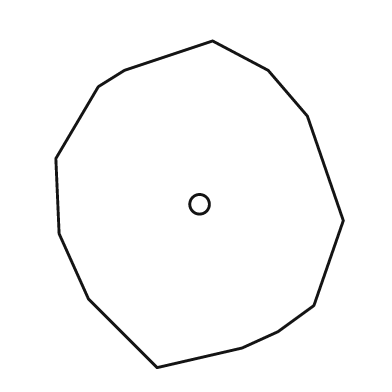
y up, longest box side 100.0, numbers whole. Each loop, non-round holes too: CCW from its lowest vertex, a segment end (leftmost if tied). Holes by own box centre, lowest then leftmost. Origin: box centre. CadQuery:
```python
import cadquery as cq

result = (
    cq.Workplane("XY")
    .moveTo(-13.0, -50.0)
    .lineTo(13.0, -44.0)
    .lineTo(24.0, -39.0)
    .lineTo(35.0, -31.0)
    .lineTo(44.0, -5.0)
    .lineTo(33.0, 27.0)
    .lineTo(21.0, 41.0)
    .lineTo(4.0, 50.0)
    .lineTo(-23.0, 41.0)
    .lineTo(-31.0, 36.0)
    .lineTo(-44.0, 14.0)
    .lineTo(-43.0, -9.0)
    .lineTo(-34.0, -29.0)
    .close()
    .moveTo(0.0, 0.0)
    .circle(3.0)
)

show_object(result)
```